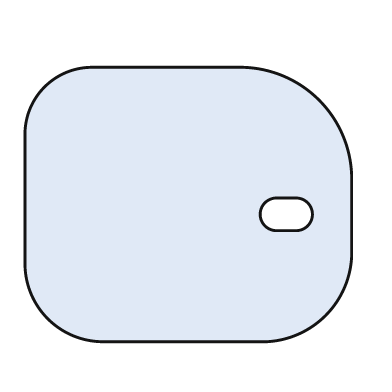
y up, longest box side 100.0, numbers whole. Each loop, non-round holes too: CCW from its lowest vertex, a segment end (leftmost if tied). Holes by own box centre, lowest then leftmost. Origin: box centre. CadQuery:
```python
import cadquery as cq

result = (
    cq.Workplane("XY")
    .moveTo(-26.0, -42.0)
    .lineTo(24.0, -42.0)
    .threePointArc((42.0, -34.0), (50.0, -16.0))
    .lineTo(50.0, 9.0)
    .threePointArc((40.0, 32.0), (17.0, 42.0))
    .lineTo(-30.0, 42.0)
    .threePointArc((-44.0, 36.0), (-50.0, 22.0))
    .lineTo(-50.0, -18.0)
    .threePointArc((-43.0, -35.0), (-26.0, -42.0))
    .close()
    .moveTo(27.0, -8.0)
    .lineTo(33.0, -8.0)
    .threePointArc((38.0, -3.0), (33.0, 2.0))
    .lineTo(27.0, 2.0)
    .threePointArc((22.0, -3.0), (27.0, -8.0))
    .close()
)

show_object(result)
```